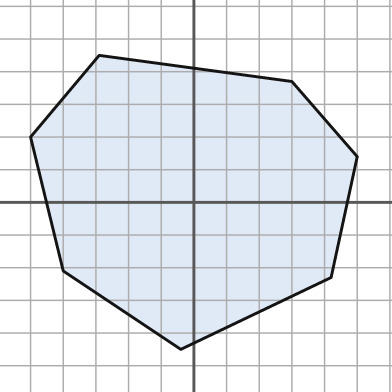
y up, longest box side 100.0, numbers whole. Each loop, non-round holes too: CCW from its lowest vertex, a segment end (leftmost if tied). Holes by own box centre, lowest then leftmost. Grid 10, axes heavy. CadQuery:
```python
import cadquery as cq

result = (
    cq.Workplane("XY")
    .moveTo(-4.0, -45.0)
    .lineTo(42.0, -23.0)
    .lineTo(50.0, 14.0)
    .lineTo(30.0, 37.0)
    .lineTo(-29.0, 45.0)
    .lineTo(-50.0, 20.0)
    .lineTo(-40.0, -21.0)
    .close()
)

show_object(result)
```